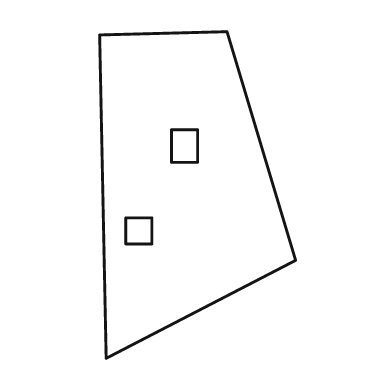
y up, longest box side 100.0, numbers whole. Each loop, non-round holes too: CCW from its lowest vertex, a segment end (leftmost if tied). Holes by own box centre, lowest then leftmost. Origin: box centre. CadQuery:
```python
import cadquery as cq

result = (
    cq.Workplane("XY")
    .moveTo(-28.0, -50.0)
    .lineTo(30.0, -20.0)
    .lineTo(9.0, 50.0)
    .lineTo(-30.0, 49.0)
    .close()
    .moveTo(-22.0, -15.0)
    .lineTo(-14.0, -15.0)
    .lineTo(-14.0, -7.0)
    .lineTo(-22.0, -7.0)
    .close()
    .moveTo(-8.0, 10.0)
    .lineTo(0.0, 10.0)
    .lineTo(0.0, 20.0)
    .lineTo(-8.0, 20.0)
    .close()
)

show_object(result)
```